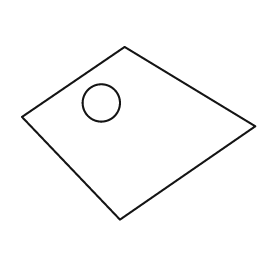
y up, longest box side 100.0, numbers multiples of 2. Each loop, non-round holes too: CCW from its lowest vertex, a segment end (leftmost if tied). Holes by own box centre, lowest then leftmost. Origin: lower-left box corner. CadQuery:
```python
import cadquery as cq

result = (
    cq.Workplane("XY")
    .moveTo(42.0, 0.0)
    .lineTo(100.0, 40.0)
    .lineTo(44.0, 74.0)
    .lineTo(0.0, 44.0)
    .close()
    .moveTo(34.0, 50.0)
    .circle(8.0)
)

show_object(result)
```